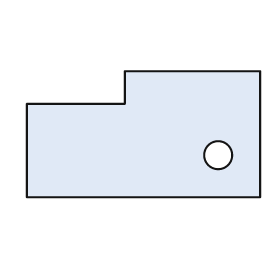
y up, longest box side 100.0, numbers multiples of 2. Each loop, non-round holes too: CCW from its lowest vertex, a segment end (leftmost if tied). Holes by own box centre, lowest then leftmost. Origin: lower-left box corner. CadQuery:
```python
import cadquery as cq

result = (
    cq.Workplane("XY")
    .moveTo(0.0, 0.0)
    .lineTo(100.0, 0.0)
    .lineTo(100.0, 54.0)
    .lineTo(42.0, 54.0)
    .lineTo(42.0, 40.0)
    .lineTo(0.0, 40.0)
    .close()
    .moveTo(82.0, 18.0)
    .circle(6.0)
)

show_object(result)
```